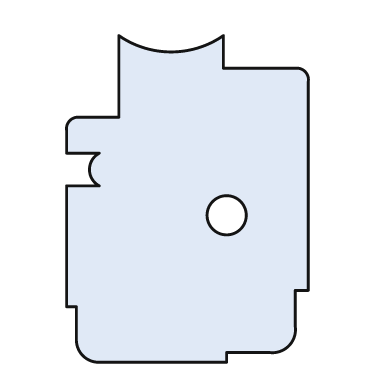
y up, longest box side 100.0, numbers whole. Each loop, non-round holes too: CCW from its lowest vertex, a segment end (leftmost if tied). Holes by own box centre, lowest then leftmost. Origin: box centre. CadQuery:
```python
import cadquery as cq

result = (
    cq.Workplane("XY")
    .moveTo(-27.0, -50.0)
    .lineTo(12.0, -50.0)
    .lineTo(12.0, -47.0)
    .lineTo(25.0, -47.0)
    .threePointArc((31.0, -45.0), (33.0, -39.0))
    .lineTo(33.0, -28.0)
    .lineTo(37.0, -28.0)
    .lineTo(37.0, 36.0)
    .threePointArc((36.0, 39.0), (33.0, 40.0))
    .lineTo(11.0, 40.0)
    .lineTo(11.0, 50.0)
    .threePointArc((-5.0, 45.0), (-21.0, 50.0))
    .lineTo(-21.0, 25.0)
    .lineTo(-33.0, 25.0)
    .threePointArc((-36.0, 24.0), (-37.0, 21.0))
    .lineTo(-37.0, 14.0)
    .lineTo(-27.0, 14.0)
    .threePointArc((-30.0, 9.0), (-27.0, 4.0))
    .lineTo(-37.0, 4.0)
    .lineTo(-37.0, -33.0)
    .lineTo(-34.0, -33.0)
    .lineTo(-34.0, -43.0)
    .threePointArc((-32.0, -48.0), (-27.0, -50.0))
    .close()
    .moveTo(12.0, -5.0)
    .circle(6.0)
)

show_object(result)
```